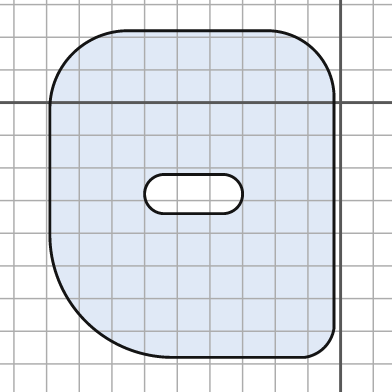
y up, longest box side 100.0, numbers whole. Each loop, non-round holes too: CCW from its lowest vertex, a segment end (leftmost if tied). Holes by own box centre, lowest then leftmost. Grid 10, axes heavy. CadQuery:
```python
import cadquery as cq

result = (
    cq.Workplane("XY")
    .moveTo(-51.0, -78.0)
    .lineTo(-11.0, -78.0)
    .threePointArc((-5.0, -75.0), (-2.0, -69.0))
    .lineTo(-2.0, 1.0)
    .threePointArc((-8.0, 16.0), (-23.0, 22.0))
    .lineTo(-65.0, 22.0)
    .threePointArc((-82.0, 15.0), (-89.0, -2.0))
    .lineTo(-89.0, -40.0)
    .threePointArc((-78.0, -67.0), (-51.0, -78.0))
    .close()
    .moveTo(-54.0, -34.0)
    .lineTo(-36.0, -34.0)
    .threePointArc((-30.0, -28.0), (-36.0, -22.0))
    .lineTo(-54.0, -22.0)
    .threePointArc((-60.0, -28.0), (-54.0, -34.0))
    .close()
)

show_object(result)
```